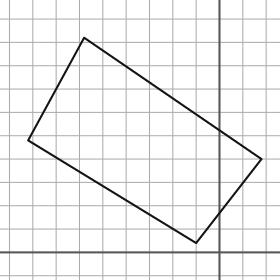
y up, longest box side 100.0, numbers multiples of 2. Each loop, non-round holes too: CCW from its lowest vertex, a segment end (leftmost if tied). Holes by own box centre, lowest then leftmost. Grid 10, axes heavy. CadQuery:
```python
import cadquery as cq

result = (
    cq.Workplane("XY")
    .moveTo(-10.0, 4.0)
    .lineTo(18.0, 40.0)
    .lineTo(-58.0, 92.0)
    .lineTo(-82.0, 48.0)
    .close()
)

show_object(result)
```